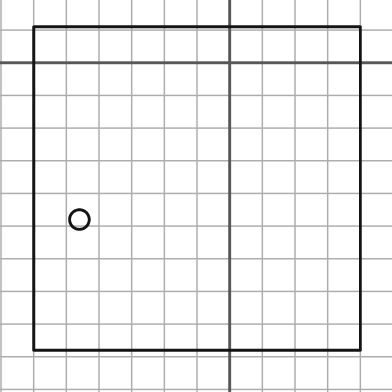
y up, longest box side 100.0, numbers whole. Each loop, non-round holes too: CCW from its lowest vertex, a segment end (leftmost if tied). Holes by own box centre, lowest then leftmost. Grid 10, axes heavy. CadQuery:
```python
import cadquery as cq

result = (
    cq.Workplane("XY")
    .moveTo(-60.0, -88.0)
    .lineTo(40.0, -88.0)
    .lineTo(40.0, 11.0)
    .lineTo(-60.0, 11.0)
    .close()
    .moveTo(-46.0, -48.0)
    .circle(3.0)
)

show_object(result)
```